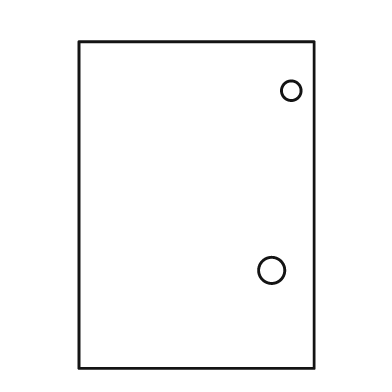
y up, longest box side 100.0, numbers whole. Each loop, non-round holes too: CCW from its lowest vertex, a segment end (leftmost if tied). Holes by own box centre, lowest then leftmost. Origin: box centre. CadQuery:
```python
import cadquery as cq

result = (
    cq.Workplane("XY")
    .moveTo(-36.0, -50.0)
    .lineTo(36.0, -50.0)
    .lineTo(36.0, 50.0)
    .lineTo(-36.0, 50.0)
    .close()
    .moveTo(23.0, -20.0)
    .circle(4.0)
    .moveTo(29.0, 35.0)
    .circle(3.0)
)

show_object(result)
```